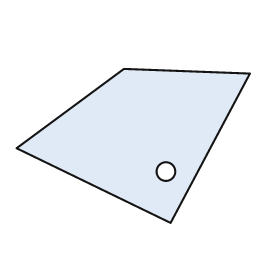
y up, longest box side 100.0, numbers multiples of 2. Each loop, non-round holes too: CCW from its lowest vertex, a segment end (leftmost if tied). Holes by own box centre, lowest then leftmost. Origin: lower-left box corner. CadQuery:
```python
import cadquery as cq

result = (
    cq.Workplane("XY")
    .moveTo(66.0, 0.0)
    .lineTo(100.0, 64.0)
    .lineTo(46.0, 66.0)
    .lineTo(0.0, 32.0)
    .close()
    .moveTo(64.0, 22.0)
    .circle(4.0)
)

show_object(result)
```